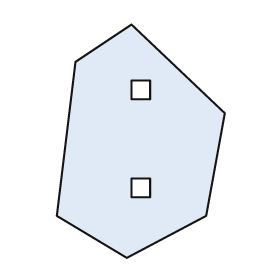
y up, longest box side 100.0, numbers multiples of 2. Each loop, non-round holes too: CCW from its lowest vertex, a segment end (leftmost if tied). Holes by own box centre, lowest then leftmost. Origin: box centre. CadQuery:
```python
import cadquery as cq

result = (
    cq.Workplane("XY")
    .moveTo(-6.0, -50.0)
    .lineTo(28.0, -32.0)
    .lineTo(36.0, 12.0)
    .lineTo(-4.0, 50.0)
    .lineTo(-28.0, 34.0)
    .lineTo(-36.0, -32.0)
    .close()
    .moveTo(-4.0, -24.0)
    .lineTo(4.0, -24.0)
    .lineTo(4.0, -16.0)
    .lineTo(-4.0, -16.0)
    .close()
    .moveTo(-4.0, 18.0)
    .lineTo(4.0, 18.0)
    .lineTo(4.0, 26.0)
    .lineTo(-4.0, 26.0)
    .close()
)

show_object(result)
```